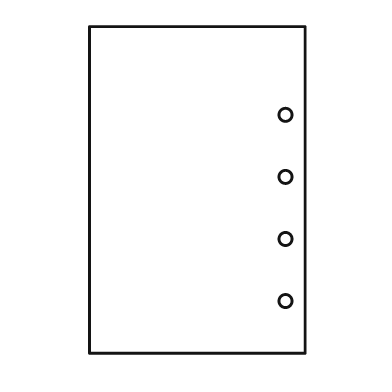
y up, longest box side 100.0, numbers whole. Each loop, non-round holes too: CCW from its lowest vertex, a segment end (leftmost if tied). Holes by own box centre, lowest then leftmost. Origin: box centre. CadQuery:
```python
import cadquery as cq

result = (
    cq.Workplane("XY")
    .moveTo(-33.0, -50.0)
    .lineTo(33.0, -50.0)
    .lineTo(33.0, 50.0)
    .lineTo(-33.0, 50.0)
    .close()
    .moveTo(27.0, -34.0)
    .circle(2.0)
    .moveTo(27.0, -15.0)
    .circle(2.0)
    .moveTo(27.0, 4.0)
    .circle(2.0)
    .moveTo(27.0, 23.0)
    .circle(2.0)
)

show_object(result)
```